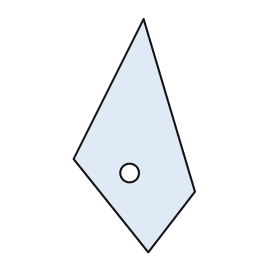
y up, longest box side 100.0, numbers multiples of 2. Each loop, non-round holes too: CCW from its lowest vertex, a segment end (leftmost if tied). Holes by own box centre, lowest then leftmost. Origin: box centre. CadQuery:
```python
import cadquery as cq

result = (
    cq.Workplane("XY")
    .moveTo(6.0, -50.0)
    .lineTo(26.0, -24.0)
    .lineTo(4.0, 50.0)
    .lineTo(-26.0, -10.0)
    .close()
    .moveTo(-2.0, -16.0)
    .circle(4.0)
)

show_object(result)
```